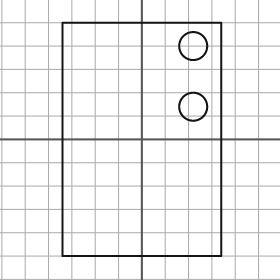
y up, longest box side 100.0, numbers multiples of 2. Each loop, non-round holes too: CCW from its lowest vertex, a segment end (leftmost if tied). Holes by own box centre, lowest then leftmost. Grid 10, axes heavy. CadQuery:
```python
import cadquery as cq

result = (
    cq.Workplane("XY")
    .moveTo(-34.0, -50.0)
    .lineTo(34.0, -50.0)
    .lineTo(34.0, 50.0)
    .lineTo(-34.0, 50.0)
    .close()
    .moveTo(22.0, 14.0)
    .circle(6.0)
    .moveTo(22.0, 40.0)
    .circle(6.0)
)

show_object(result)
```